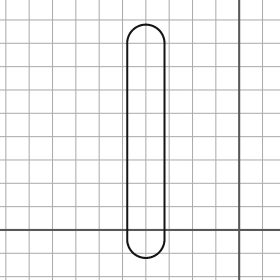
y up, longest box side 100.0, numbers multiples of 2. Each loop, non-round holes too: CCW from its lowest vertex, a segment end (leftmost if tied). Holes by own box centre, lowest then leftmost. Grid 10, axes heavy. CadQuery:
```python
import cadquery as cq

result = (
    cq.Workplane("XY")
    .moveTo(-48.0, -4.0)
    .threePointArc((-40.0, -12.0), (-32.0, -4.0))
    .lineTo(-32.0, 80.0)
    .threePointArc((-40.0, 88.0), (-48.0, 80.0))
    .close()
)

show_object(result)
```